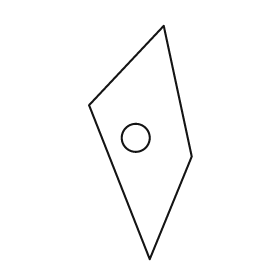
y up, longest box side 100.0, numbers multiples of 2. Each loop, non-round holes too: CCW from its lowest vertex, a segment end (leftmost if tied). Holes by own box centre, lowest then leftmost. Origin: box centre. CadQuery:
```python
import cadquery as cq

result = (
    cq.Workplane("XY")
    .moveTo(4.0, -50.0)
    .lineTo(22.0, -6.0)
    .lineTo(10.0, 50.0)
    .lineTo(-22.0, 16.0)
    .close()
    .moveTo(-2.0, 2.0)
    .circle(6.0)
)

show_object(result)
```